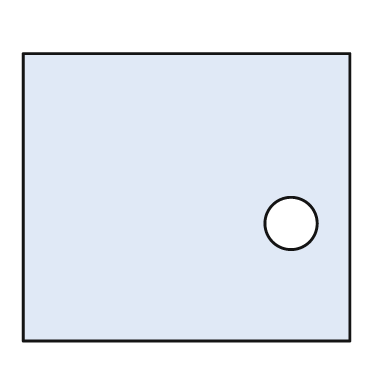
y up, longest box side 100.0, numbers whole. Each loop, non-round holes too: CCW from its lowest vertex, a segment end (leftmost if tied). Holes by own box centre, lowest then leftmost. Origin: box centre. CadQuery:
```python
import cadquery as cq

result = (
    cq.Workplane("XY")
    .moveTo(-50.0, -44.0)
    .lineTo(50.0, -44.0)
    .lineTo(50.0, 44.0)
    .lineTo(-50.0, 44.0)
    .close()
    .moveTo(32.0, -8.0)
    .circle(8.0)
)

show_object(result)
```